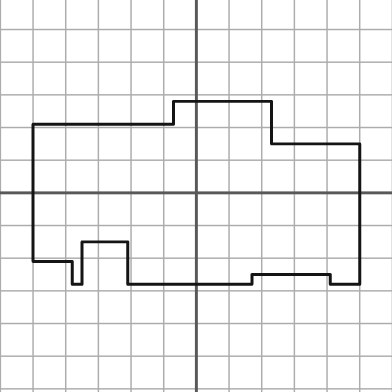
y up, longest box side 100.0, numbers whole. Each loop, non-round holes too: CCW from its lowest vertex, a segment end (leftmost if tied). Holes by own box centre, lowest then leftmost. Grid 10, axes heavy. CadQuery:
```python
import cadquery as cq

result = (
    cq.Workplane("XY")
    .moveTo(-38.0, -28.0)
    .lineTo(-35.0, -28.0)
    .lineTo(-35.0, -15.0)
    .lineTo(-21.0, -15.0)
    .lineTo(-21.0, -28.0)
    .lineTo(17.0, -28.0)
    .lineTo(17.0, -25.0)
    .lineTo(41.0, -25.0)
    .lineTo(41.0, -28.0)
    .lineTo(50.0, -28.0)
    .lineTo(50.0, 15.0)
    .lineTo(23.0, 15.0)
    .lineTo(23.0, 28.0)
    .lineTo(-7.0, 28.0)
    .lineTo(-7.0, 21.0)
    .lineTo(-50.0, 21.0)
    .lineTo(-50.0, -21.0)
    .lineTo(-38.0, -21.0)
    .close()
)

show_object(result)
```